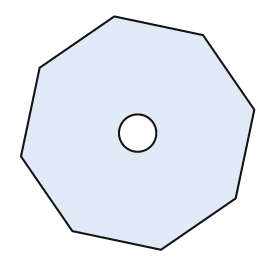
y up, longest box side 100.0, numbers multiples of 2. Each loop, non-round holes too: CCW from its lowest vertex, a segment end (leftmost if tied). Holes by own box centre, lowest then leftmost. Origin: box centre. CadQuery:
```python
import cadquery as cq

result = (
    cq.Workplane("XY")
    .moveTo(10.0, -50.0)
    .lineTo(42.0, -28.0)
    .lineTo(50.0, 10.0)
    .lineTo(28.0, 42.0)
    .lineTo(-10.0, 50.0)
    .lineTo(-42.0, 28.0)
    .lineTo(-50.0, -10.0)
    .lineTo(-28.0, -42.0)
    .close()
    .moveTo(0.0, 0.0)
    .circle(8.0)
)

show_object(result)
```